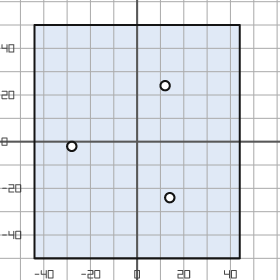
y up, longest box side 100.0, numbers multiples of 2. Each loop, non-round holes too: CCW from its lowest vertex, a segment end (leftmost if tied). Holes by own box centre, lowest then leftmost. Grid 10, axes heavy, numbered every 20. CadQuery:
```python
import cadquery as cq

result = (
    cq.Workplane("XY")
    .moveTo(-44.0, -50.0)
    .lineTo(44.0, -50.0)
    .lineTo(44.0, 50.0)
    .lineTo(-44.0, 50.0)
    .close()
    .moveTo(14.0, -24.0)
    .circle(2.0)
    .moveTo(-28.0, -2.0)
    .circle(2.0)
    .moveTo(12.0, 24.0)
    .circle(2.0)
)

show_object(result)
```